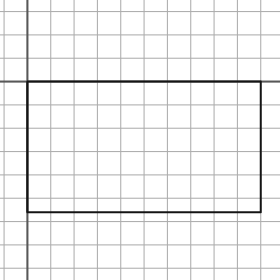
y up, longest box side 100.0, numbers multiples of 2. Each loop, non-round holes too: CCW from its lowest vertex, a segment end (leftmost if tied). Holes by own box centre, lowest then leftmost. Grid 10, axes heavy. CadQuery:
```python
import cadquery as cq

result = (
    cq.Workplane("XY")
    .moveTo(0.0, -56.0)
    .lineTo(100.0, -56.0)
    .lineTo(100.0, 0.0)
    .lineTo(0.0, 0.0)
    .close()
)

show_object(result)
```